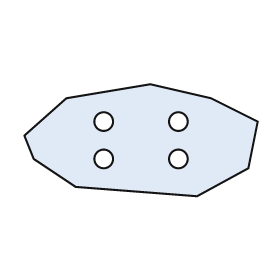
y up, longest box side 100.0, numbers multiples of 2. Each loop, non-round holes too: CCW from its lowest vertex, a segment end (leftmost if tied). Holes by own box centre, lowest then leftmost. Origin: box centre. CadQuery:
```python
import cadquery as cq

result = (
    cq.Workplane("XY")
    .moveTo(24.0, -24.0)
    .lineTo(46.0, -12.0)
    .lineTo(50.0, 8.0)
    .lineTo(30.0, 18.0)
    .lineTo(4.0, 24.0)
    .lineTo(-32.0, 18.0)
    .lineTo(-50.0, 2.0)
    .lineTo(-46.0, -8.0)
    .lineTo(-28.0, -20.0)
    .close()
    .moveTo(-16.0, -8.0)
    .circle(4.0)
    .moveTo(16.0, -8.0)
    .circle(4.0)
    .moveTo(-16.0, 8.0)
    .circle(4.0)
    .moveTo(16.0, 8.0)
    .circle(4.0)
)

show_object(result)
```